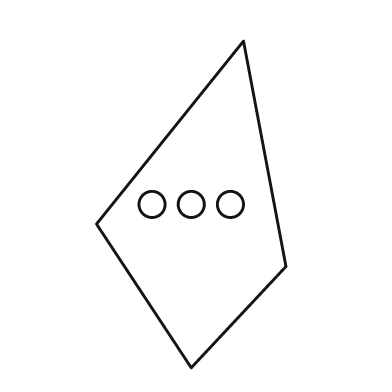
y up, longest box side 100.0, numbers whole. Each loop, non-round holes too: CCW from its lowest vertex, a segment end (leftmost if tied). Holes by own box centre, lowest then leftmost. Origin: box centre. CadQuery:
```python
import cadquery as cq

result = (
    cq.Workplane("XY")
    .moveTo(0.0, -50.0)
    .lineTo(29.0, -19.0)
    .lineTo(16.0, 50.0)
    .lineTo(-29.0, -6.0)
    .close()
    .moveTo(-12.0, 0.0)
    .circle(4.0)
    .moveTo(0.0, 0.0)
    .circle(4.0)
    .moveTo(12.0, 0.0)
    .circle(4.0)
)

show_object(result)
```